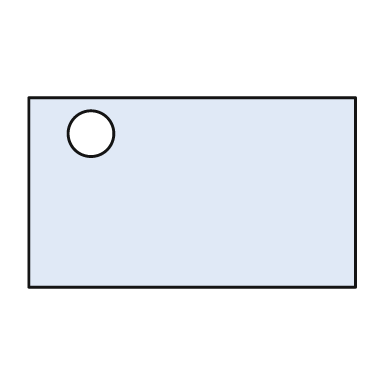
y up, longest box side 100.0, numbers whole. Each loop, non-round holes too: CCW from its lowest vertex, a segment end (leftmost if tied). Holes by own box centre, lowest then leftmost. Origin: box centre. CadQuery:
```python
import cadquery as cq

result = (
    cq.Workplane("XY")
    .moveTo(-50.0, -29.0)
    .lineTo(50.0, -29.0)
    .lineTo(50.0, 29.0)
    .lineTo(-50.0, 29.0)
    .close()
    .moveTo(-31.0, 18.0)
    .circle(7.0)
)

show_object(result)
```